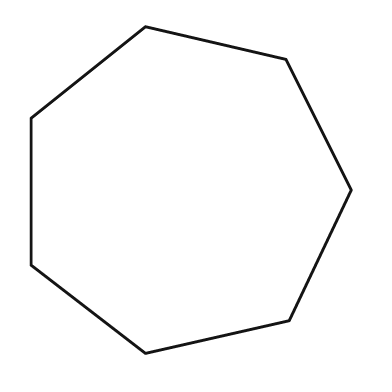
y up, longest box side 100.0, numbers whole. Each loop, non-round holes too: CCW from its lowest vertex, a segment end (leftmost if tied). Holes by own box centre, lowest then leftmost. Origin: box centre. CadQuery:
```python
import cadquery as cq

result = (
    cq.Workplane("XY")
    .moveTo(-14.0, -50.0)
    .lineTo(30.0, -40.0)
    .lineTo(49.0, 0.0)
    .lineTo(29.0, 40.0)
    .lineTo(-14.0, 50.0)
    .lineTo(-49.0, 22.0)
    .lineTo(-49.0, -23.0)
    .close()
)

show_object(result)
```